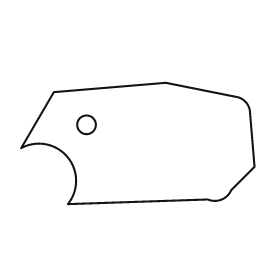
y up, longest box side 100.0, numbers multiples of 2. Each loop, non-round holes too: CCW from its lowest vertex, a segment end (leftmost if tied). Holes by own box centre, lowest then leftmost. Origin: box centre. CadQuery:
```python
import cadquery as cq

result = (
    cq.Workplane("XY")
    .moveTo(-30.0, -26.0)
    .lineTo(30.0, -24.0)
    .threePointArc((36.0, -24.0), (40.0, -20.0))
    .lineTo(50.0, -10.0)
    .lineTo(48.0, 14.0)
    .threePointArc((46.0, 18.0), (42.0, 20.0))
    .lineTo(12.0, 26.0)
    .lineTo(-36.0, 22.0)
    .lineTo(-50.0, -2.0)
    .threePointArc((-30.0, -6.0), (-30.0, -26.0))
    .close()
    .moveTo(-22.0, 8.0)
    .circle(4.0)
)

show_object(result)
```